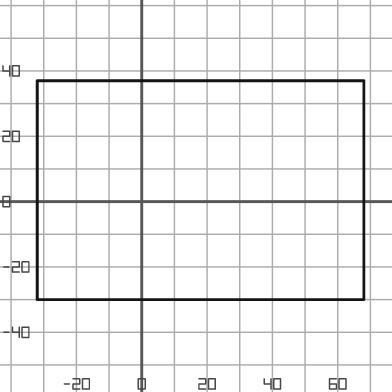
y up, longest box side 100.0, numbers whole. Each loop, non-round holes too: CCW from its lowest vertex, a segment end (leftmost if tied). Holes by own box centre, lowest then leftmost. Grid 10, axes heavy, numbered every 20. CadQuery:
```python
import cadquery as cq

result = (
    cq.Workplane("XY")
    .moveTo(-32.0, -30.0)
    .lineTo(68.0, -30.0)
    .lineTo(68.0, 37.0)
    .lineTo(-32.0, 37.0)
    .close()
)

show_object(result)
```